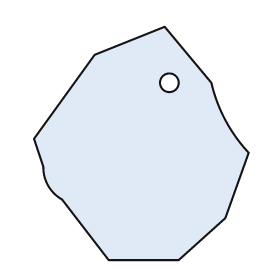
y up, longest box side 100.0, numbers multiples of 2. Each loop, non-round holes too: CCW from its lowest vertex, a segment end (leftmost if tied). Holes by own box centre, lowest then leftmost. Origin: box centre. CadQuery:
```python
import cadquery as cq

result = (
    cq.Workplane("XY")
    .moveTo(-14.0, -50.0)
    .lineTo(16.0, -50.0)
    .lineTo(36.0, -32.0)
    .lineTo(46.0, -4.0)
    .threePointArc((36.0, 10.0), (30.0, 26.0))
    .lineTo(10.0, 50.0)
    .lineTo(-20.0, 38.0)
    .lineTo(-46.0, 2.0)
    .lineTo(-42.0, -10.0)
    .threePointArc((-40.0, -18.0), (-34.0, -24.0))
    .close()
    .moveTo(12.0, 26.0)
    .circle(4.0)
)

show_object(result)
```